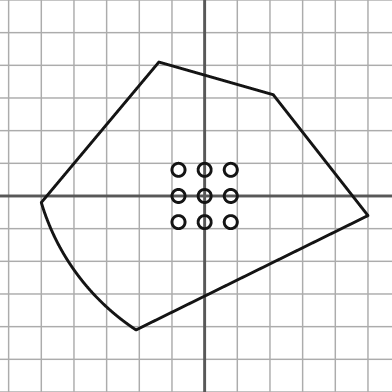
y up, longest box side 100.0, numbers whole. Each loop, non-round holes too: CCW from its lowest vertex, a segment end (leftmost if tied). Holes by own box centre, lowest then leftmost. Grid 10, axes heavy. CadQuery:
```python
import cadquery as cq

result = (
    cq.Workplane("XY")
    .moveTo(-21.0, -41.0)
    .lineTo(50.0, -6.0)
    .lineTo(21.0, 31.0)
    .lineTo(-14.0, 41.0)
    .lineTo(-50.0, -2.0)
    .threePointArc((-39.0, -24.0), (-21.0, -41.0))
    .close()
    .moveTo(-8.0, -8.0)
    .circle(2.0)
    .moveTo(0.0, -8.0)
    .circle(2.0)
    .moveTo(8.0, -8.0)
    .circle(2.0)
    .moveTo(-8.0, 0.0)
    .circle(2.0)
    .moveTo(0.0, 0.0)
    .circle(2.0)
    .moveTo(8.0, 0.0)
    .circle(2.0)
    .moveTo(-8.0, 8.0)
    .circle(2.0)
    .moveTo(0.0, 8.0)
    .circle(2.0)
    .moveTo(8.0, 8.0)
    .circle(2.0)
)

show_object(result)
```